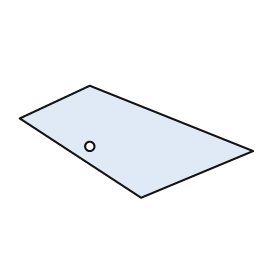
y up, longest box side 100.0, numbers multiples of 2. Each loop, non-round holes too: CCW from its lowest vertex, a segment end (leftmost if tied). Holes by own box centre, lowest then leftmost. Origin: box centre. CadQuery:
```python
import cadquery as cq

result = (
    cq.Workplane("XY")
    .moveTo(2.0, -24.0)
    .lineTo(50.0, -4.0)
    .lineTo(-20.0, 24.0)
    .lineTo(-50.0, 10.0)
    .close()
    .moveTo(-20.0, -2.0)
    .circle(2.0)
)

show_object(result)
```